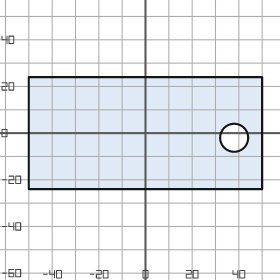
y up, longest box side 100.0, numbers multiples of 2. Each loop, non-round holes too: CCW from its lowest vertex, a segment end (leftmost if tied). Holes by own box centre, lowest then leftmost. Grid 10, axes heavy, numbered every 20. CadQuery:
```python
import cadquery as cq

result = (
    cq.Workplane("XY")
    .moveTo(-50.0, -24.0)
    .lineTo(50.0, -24.0)
    .lineTo(50.0, 24.0)
    .lineTo(-50.0, 24.0)
    .close()
    .moveTo(38.0, -2.0)
    .circle(6.0)
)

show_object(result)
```